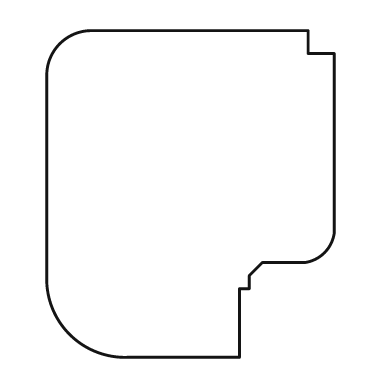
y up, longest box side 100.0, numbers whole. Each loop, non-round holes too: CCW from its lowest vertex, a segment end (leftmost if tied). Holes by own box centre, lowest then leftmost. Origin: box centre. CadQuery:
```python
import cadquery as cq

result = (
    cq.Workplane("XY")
    .moveTo(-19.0, -50.0)
    .lineTo(15.0, -50.0)
    .lineTo(15.0, -29.0)
    .lineTo(18.0, -29.0)
    .lineTo(18.0, -25.0)
    .lineTo(22.0, -21.0)
    .lineTo(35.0, -21.0)
    .threePointArc((41.0, -18.0), (44.0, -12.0))
    .lineTo(44.0, 43.0)
    .lineTo(36.0, 43.0)
    .lineTo(36.0, 50.0)
    .lineTo(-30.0, 50.0)
    .threePointArc((-40.0, 46.0), (-44.0, 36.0))
    .lineTo(-44.0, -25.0)
    .threePointArc((-37.0, -43.0), (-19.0, -50.0))
    .close()
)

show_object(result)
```